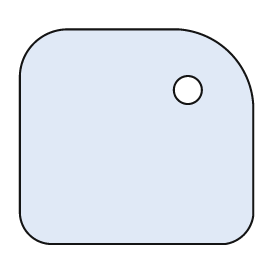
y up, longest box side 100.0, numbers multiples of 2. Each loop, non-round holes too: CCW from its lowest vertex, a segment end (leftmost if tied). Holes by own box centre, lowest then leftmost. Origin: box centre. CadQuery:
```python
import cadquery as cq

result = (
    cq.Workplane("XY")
    .moveTo(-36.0, -46.0)
    .lineTo(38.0, -46.0)
    .threePointArc((46.0, -42.0), (50.0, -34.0))
    .lineTo(50.0, 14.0)
    .threePointArc((40.0, 36.0), (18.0, 46.0))
    .lineTo(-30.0, 46.0)
    .threePointArc((-44.0, 40.0), (-50.0, 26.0))
    .lineTo(-50.0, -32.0)
    .threePointArc((-46.0, -42.0), (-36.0, -46.0))
    .close()
    .moveTo(22.0, 20.0)
    .circle(6.0)
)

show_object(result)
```